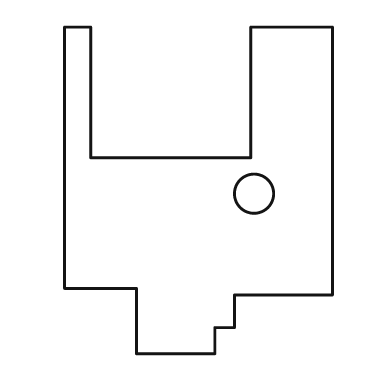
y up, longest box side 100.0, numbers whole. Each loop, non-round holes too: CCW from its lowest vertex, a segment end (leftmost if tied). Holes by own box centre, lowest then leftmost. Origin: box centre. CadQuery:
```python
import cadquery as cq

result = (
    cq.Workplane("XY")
    .moveTo(-19.0, -50.0)
    .lineTo(5.0, -50.0)
    .lineTo(5.0, -42.0)
    .lineTo(11.0, -42.0)
    .lineTo(11.0, -32.0)
    .lineTo(41.0, -32.0)
    .lineTo(41.0, 50.0)
    .lineTo(16.0, 50.0)
    .lineTo(16.0, 10.0)
    .lineTo(-33.0, 10.0)
    .lineTo(-33.0, 50.0)
    .lineTo(-41.0, 50.0)
    .lineTo(-41.0, -30.0)
    .lineTo(-19.0, -30.0)
    .close()
    .moveTo(17.0, -1.0)
    .circle(6.0)
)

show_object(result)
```